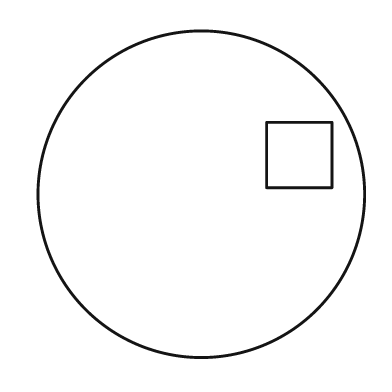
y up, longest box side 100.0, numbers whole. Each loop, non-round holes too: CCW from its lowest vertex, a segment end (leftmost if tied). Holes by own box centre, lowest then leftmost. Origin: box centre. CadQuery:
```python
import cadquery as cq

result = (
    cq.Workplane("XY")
    .moveTo(0.0, 0.0)
    .circle(50.0)
    .moveTo(20.0, 2.0)
    .lineTo(40.0, 2.0)
    .lineTo(40.0, 22.0)
    .lineTo(20.0, 22.0)
    .close()
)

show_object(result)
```